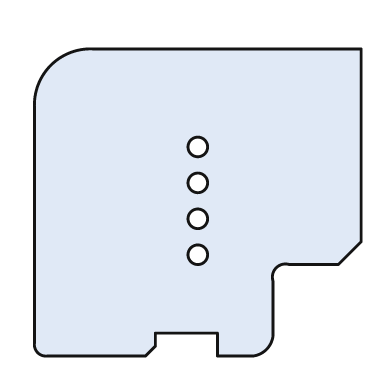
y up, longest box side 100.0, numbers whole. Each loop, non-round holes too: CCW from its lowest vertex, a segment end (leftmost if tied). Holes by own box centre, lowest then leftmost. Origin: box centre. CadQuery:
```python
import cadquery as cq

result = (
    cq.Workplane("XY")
    .moveTo(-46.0, -47.0)
    .lineTo(-16.0, -47.0)
    .lineTo(-13.0, -44.0)
    .lineTo(-13.0, -40.0)
    .lineTo(6.0, -40.0)
    .lineTo(6.0, -47.0)
    .lineTo(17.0, -47.0)
    .threePointArc((21.0, -45.0), (23.0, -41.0))
    .lineTo(23.0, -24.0)
    .threePointArc((24.0, -20.0), (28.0, -19.0))
    .lineTo(43.0, -19.0)
    .lineTo(50.0, -12.0)
    .lineTo(50.0, 47.0)
    .lineTo(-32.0, 47.0)
    .threePointArc((-45.0, 42.0), (-50.0, 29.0))
    .lineTo(-50.0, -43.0)
    .threePointArc((-49.0, -46.0), (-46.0, -47.0))
    .close()
    .moveTo(0.0, -16.0)
    .circle(3.0)
    .moveTo(0.0, -5.0)
    .circle(3.0)
    .moveTo(0.0, 6.0)
    .circle(3.0)
    .moveTo(0.0, 17.0)
    .circle(3.0)
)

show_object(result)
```